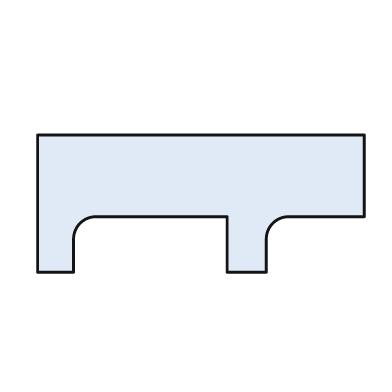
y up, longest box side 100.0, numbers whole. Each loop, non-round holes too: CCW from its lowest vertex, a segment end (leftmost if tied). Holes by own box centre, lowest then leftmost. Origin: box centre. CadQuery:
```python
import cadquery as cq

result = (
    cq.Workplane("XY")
    .moveTo(-50.0, -21.0)
    .lineTo(-39.0, -21.0)
    .lineTo(-39.0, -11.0)
    .threePointArc((-37.0, -6.0), (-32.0, -4.0))
    .lineTo(8.0, -4.0)
    .lineTo(8.0, -21.0)
    .lineTo(20.0, -21.0)
    .lineTo(20.0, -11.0)
    .threePointArc((22.0, -6.0), (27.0, -4.0))
    .lineTo(50.0, -4.0)
    .lineTo(50.0, 21.0)
    .lineTo(-50.0, 21.0)
    .close()
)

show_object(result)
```